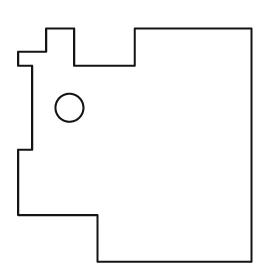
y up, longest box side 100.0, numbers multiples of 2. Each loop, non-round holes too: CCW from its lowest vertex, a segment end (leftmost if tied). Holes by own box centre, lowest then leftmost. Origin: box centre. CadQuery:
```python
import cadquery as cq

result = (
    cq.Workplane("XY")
    .moveTo(-16.0, -50.0)
    .lineTo(50.0, -50.0)
    .lineTo(50.0, 50.0)
    .lineTo(0.0, 50.0)
    .lineTo(0.0, 34.0)
    .lineTo(-26.0, 34.0)
    .lineTo(-26.0, 50.0)
    .lineTo(-38.0, 50.0)
    .lineTo(-38.0, 40.0)
    .lineTo(-50.0, 40.0)
    .lineTo(-50.0, 34.0)
    .lineTo(-44.0, 34.0)
    .lineTo(-44.0, -2.0)
    .lineTo(-50.0, -2.0)
    .lineTo(-50.0, -30.0)
    .lineTo(-16.0, -30.0)
    .close()
    .moveTo(-28.0, 16.0)
    .circle(6.0)
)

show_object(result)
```